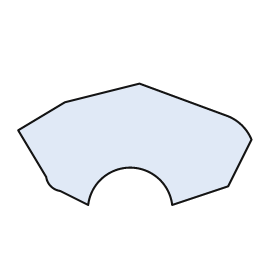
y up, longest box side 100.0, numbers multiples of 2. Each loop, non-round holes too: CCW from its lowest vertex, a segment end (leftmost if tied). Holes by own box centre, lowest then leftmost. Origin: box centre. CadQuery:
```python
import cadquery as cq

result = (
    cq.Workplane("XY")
    .moveTo(-20.0, -26.0)
    .threePointArc((-2.0, -10.0), (16.0, -26.0))
    .lineTo(40.0, -18.0)
    .lineTo(50.0, 2.0)
    .threePointArc((46.0, 8.0), (40.0, 12.0))
    .lineTo(2.0, 26.0)
    .lineTo(-30.0, 18.0)
    .lineTo(-50.0, 6.0)
    .lineTo(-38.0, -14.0)
    .threePointArc((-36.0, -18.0), (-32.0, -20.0))
    .close()
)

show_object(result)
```